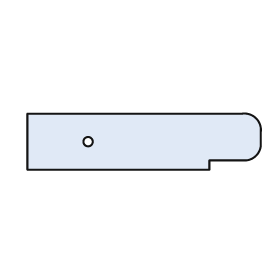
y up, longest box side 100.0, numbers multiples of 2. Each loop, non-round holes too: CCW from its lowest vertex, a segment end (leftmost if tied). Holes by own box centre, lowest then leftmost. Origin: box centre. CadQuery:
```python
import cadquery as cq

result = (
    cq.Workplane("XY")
    .moveTo(-50.0, -12.0)
    .lineTo(28.0, -12.0)
    .lineTo(28.0, -8.0)
    .lineTo(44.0, -8.0)
    .threePointArc((48.0, -6.0), (50.0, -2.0))
    .lineTo(50.0, 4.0)
    .threePointArc((48.0, 10.0), (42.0, 12.0))
    .lineTo(-50.0, 12.0)
    .close()
    .moveTo(-24.0, 0.0)
    .circle(2.0)
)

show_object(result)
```